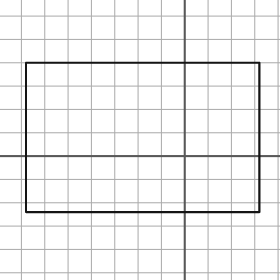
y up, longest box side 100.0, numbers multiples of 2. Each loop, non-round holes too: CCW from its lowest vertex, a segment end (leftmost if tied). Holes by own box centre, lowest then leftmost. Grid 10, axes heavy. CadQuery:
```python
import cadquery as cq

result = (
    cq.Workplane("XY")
    .moveTo(-68.0, -24.0)
    .lineTo(32.0, -24.0)
    .lineTo(32.0, 40.0)
    .lineTo(-68.0, 40.0)
    .close()
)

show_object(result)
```